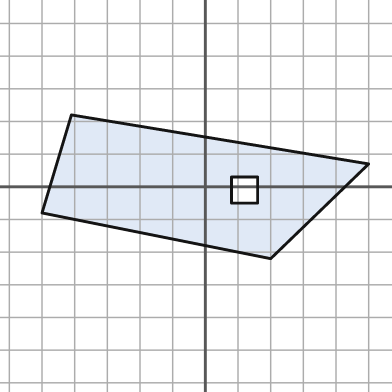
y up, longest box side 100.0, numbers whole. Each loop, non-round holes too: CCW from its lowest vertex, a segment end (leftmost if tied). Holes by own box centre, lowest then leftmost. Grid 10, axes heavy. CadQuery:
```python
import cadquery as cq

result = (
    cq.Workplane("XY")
    .moveTo(20.0, -22.0)
    .lineTo(50.0, 7.0)
    .lineTo(-41.0, 22.0)
    .lineTo(-50.0, -8.0)
    .close()
    .moveTo(8.0, -5.0)
    .lineTo(16.0, -5.0)
    .lineTo(16.0, 3.0)
    .lineTo(8.0, 3.0)
    .close()
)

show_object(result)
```